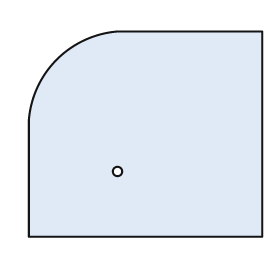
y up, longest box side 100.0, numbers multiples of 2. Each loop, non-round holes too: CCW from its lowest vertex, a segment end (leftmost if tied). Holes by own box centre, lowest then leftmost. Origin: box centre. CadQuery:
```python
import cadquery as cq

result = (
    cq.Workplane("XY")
    .moveTo(-50.0, -44.0)
    .lineTo(50.0, -44.0)
    .lineTo(50.0, 44.0)
    .lineTo(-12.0, 44.0)
    .threePointArc((-38.0, 32.0), (-50.0, 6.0))
    .close()
    .moveTo(-12.0, -16.0)
    .circle(2.0)
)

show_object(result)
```